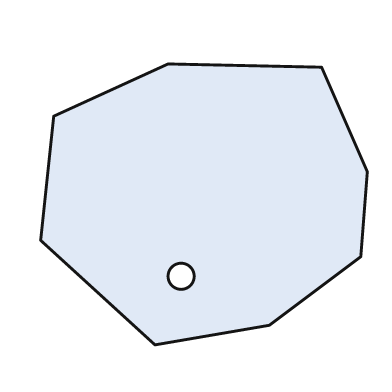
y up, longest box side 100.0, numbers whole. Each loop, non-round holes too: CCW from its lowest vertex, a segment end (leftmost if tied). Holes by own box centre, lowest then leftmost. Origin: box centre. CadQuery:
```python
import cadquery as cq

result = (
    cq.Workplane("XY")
    .moveTo(-15.0, -43.0)
    .lineTo(20.0, -37.0)
    .lineTo(48.0, -16.0)
    .lineTo(50.0, 10.0)
    .lineTo(36.0, 42.0)
    .lineTo(-11.0, 43.0)
    .lineTo(-46.0, 27.0)
    .lineTo(-50.0, -11.0)
    .close()
    .moveTo(-7.0, -22.0)
    .circle(4.0)
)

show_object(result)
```